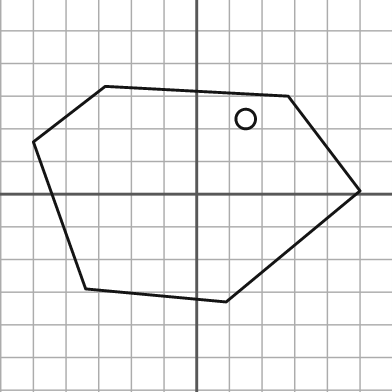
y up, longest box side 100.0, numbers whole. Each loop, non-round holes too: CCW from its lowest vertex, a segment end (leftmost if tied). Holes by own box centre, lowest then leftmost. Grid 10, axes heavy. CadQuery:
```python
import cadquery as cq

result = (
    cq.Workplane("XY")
    .moveTo(9.0, -33.0)
    .lineTo(50.0, 1.0)
    .lineTo(28.0, 30.0)
    .lineTo(-28.0, 33.0)
    .lineTo(-50.0, 16.0)
    .lineTo(-34.0, -29.0)
    .close()
    .moveTo(15.0, 23.0)
    .circle(3.0)
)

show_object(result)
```